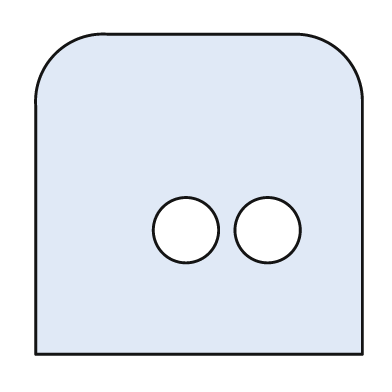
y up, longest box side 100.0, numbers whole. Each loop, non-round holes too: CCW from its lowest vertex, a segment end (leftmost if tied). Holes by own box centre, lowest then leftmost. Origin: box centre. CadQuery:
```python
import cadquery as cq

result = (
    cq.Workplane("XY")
    .moveTo(-50.0, -49.0)
    .lineTo(50.0, -49.0)
    .lineTo(50.0, 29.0)
    .threePointArc((44.0, 43.0), (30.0, 49.0))
    .lineTo(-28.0, 49.0)
    .threePointArc((-44.0, 43.0), (-50.0, 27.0))
    .close()
    .moveTo(-4.0, -11.0)
    .circle(10.0)
    .moveTo(21.0, -11.0)
    .circle(10.0)
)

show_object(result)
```